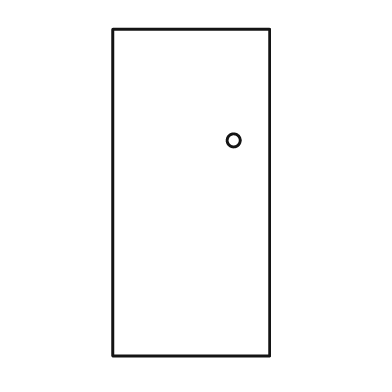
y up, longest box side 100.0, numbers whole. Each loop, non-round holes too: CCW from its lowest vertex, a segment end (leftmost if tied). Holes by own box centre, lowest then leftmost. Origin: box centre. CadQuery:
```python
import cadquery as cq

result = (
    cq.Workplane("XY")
    .moveTo(-24.0, -50.0)
    .lineTo(24.0, -50.0)
    .lineTo(24.0, 50.0)
    .lineTo(-24.0, 50.0)
    .close()
    .moveTo(13.0, 16.0)
    .circle(2.0)
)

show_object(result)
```